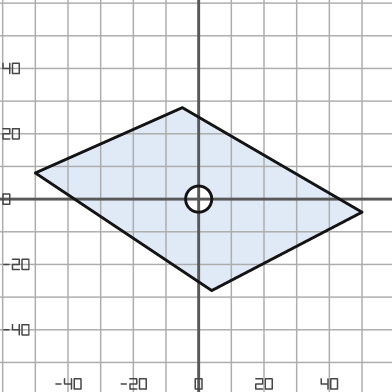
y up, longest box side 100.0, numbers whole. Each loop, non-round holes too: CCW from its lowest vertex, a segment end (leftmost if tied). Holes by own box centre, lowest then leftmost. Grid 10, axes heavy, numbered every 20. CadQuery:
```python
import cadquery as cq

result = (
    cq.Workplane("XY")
    .moveTo(4.0, -28.0)
    .lineTo(50.0, -4.0)
    .lineTo(-5.0, 28.0)
    .lineTo(-50.0, 8.0)
    .close()
    .moveTo(0.0, 0.0)
    .circle(4.0)
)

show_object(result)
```